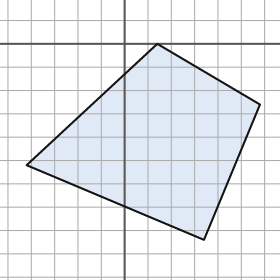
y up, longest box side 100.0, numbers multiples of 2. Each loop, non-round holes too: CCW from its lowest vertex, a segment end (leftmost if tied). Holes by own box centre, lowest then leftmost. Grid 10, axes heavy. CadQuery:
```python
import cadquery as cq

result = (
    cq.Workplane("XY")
    .moveTo(34.0, -84.0)
    .lineTo(58.0, -26.0)
    .lineTo(14.0, 0.0)
    .lineTo(-42.0, -52.0)
    .close()
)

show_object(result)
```